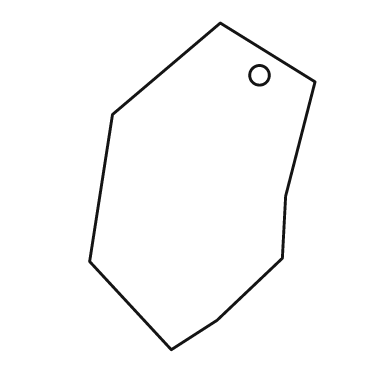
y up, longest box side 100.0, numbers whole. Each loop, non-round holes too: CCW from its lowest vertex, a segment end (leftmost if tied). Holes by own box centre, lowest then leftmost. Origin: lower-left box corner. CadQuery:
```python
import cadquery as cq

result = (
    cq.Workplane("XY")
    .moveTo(25.0, 0.0)
    .lineTo(39.0, 9.0)
    .lineTo(59.0, 28.0)
    .lineTo(60.0, 47.0)
    .lineTo(69.0, 82.0)
    .lineTo(40.0, 100.0)
    .lineTo(7.0, 72.0)
    .lineTo(0.0, 27.0)
    .close()
    .moveTo(52.0, 84.0)
    .circle(3.0)
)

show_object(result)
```